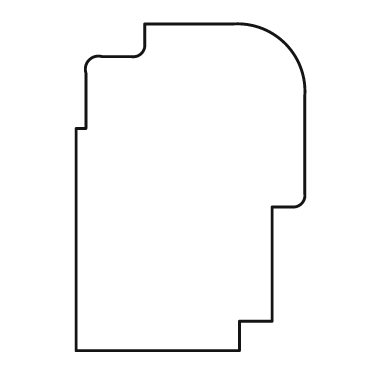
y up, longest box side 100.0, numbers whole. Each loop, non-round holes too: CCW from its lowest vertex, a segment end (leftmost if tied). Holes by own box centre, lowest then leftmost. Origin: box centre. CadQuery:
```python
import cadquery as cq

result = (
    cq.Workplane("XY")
    .moveTo(-35.0, -50.0)
    .lineTo(15.0, -50.0)
    .lineTo(15.0, -41.0)
    .lineTo(25.0, -41.0)
    .lineTo(25.0, -6.0)
    .lineTo(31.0, -6.0)
    .threePointArc((34.0, -5.0), (35.0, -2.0))
    .lineTo(35.0, 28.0)
    .threePointArc((29.0, 44.0), (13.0, 50.0))
    .lineTo(-14.0, 50.0)
    .lineTo(-14.0, 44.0)
    .threePointArc((-15.0, 41.0), (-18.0, 40.0))
    .lineTo(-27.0, 40.0)
    .threePointArc((-31.0, 39.0), (-32.0, 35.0))
    .lineTo(-32.0, 18.0)
    .lineTo(-35.0, 18.0)
    .close()
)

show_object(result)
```